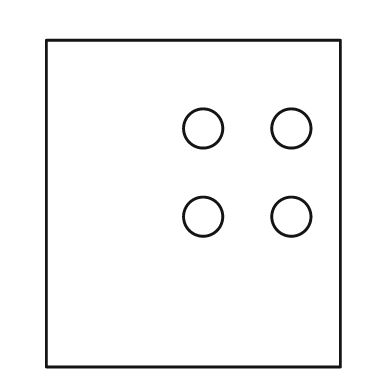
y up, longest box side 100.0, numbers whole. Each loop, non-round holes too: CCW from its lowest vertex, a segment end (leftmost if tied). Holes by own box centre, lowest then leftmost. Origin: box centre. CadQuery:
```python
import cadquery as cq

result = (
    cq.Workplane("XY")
    .moveTo(-45.0, -50.0)
    .lineTo(45.0, -50.0)
    .lineTo(45.0, 50.0)
    .lineTo(-45.0, 50.0)
    .close()
    .moveTo(3.0, -4.0)
    .circle(6.0)
    .moveTo(30.0, -4.0)
    .circle(6.0)
    .moveTo(3.0, 23.0)
    .circle(6.0)
    .moveTo(30.0, 23.0)
    .circle(6.0)
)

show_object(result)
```